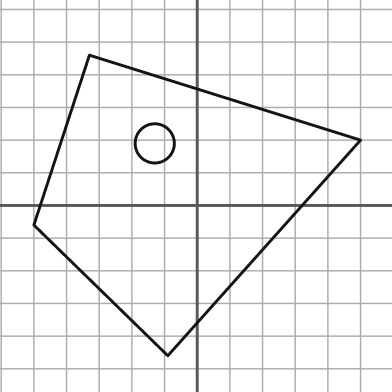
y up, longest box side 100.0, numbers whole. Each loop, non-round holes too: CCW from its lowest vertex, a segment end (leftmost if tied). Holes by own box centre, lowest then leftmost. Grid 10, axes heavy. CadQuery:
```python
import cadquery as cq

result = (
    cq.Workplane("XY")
    .moveTo(-9.0, -46.0)
    .lineTo(50.0, 20.0)
    .lineTo(-33.0, 46.0)
    .lineTo(-50.0, -6.0)
    .close()
    .moveTo(-13.0, 19.0)
    .circle(6.0)
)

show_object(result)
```